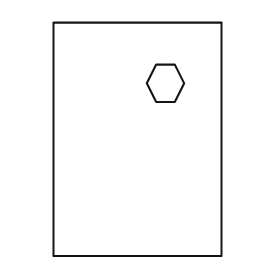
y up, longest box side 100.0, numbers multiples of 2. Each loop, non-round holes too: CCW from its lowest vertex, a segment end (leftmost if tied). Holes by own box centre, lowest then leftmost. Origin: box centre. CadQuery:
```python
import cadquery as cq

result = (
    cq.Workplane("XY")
    .moveTo(-36.0, -50.0)
    .lineTo(36.0, -50.0)
    .lineTo(36.0, 50.0)
    .lineTo(-36.0, 50.0)
    .close()
    .moveTo(8.0, 16.0)
    .lineTo(16.0, 16.0)
    .lineTo(20.0, 24.0)
    .lineTo(16.0, 32.0)
    .lineTo(8.0, 32.0)
    .lineTo(4.0, 24.0)
    .close()
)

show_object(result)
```